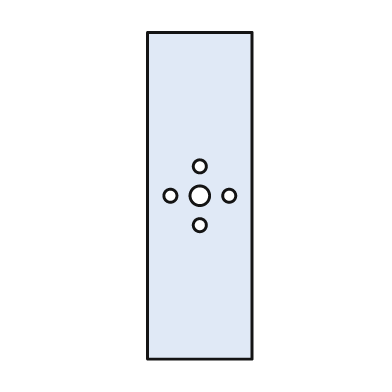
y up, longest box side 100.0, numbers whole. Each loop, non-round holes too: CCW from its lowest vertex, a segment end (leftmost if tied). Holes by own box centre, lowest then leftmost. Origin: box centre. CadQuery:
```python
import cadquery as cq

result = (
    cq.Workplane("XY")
    .moveTo(-16.0, -50.0)
    .lineTo(16.0, -50.0)
    .lineTo(16.0, 50.0)
    .lineTo(-16.0, 50.0)
    .close()
    .moveTo(0.0, -9.0)
    .circle(2.0)
    .moveTo(-9.0, 0.0)
    .circle(2.0)
    .moveTo(0.0, 0.0)
    .circle(3.0)
    .moveTo(9.0, 0.0)
    .circle(2.0)
    .moveTo(0.0, 9.0)
    .circle(2.0)
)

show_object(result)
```